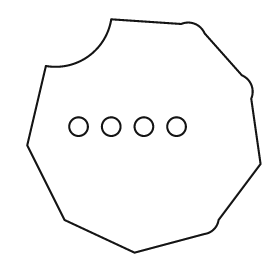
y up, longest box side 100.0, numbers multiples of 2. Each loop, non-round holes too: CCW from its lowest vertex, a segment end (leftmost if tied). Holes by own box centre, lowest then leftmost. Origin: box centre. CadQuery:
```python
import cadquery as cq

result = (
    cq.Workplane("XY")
    .moveTo(-4.0, -50.0)
    .lineTo(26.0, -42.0)
    .threePointArc((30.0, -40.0), (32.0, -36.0))
    .lineTo(50.0, -12.0)
    .lineTo(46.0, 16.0)
    .threePointArc((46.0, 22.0), (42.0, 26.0))
    .lineTo(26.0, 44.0)
    .threePointArc((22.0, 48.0), (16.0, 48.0))
    .lineTo(-14.0, 50.0)
    .threePointArc((-24.0, 34.0), (-42.0, 30.0))
    .lineTo(-50.0, -4.0)
    .lineTo(-34.0, -36.0)
    .close()
    .moveTo(-28.0, 4.0)
    .circle(4.0)
    .moveTo(-14.0, 4.0)
    .circle(4.0)
    .moveTo(0.0, 4.0)
    .circle(4.0)
    .moveTo(14.0, 4.0)
    .circle(4.0)
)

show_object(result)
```